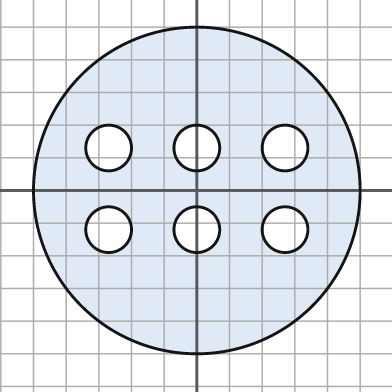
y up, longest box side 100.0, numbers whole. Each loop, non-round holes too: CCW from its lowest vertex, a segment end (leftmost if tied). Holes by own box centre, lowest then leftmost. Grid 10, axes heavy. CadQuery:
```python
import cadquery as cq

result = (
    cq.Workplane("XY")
    .moveTo(0.0, 0.0)
    .circle(50.0)
    .moveTo(-27.0, -12.0)
    .circle(7.0)
    .moveTo(0.0, -12.0)
    .circle(7.0)
    .moveTo(27.0, -12.0)
    .circle(7.0)
    .moveTo(-27.0, 13.0)
    .circle(7.0)
    .moveTo(0.0, 13.0)
    .circle(7.0)
    .moveTo(27.0, 13.0)
    .circle(7.0)
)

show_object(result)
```